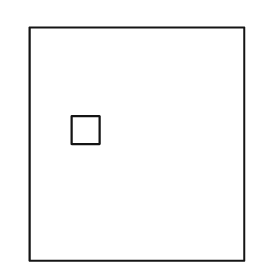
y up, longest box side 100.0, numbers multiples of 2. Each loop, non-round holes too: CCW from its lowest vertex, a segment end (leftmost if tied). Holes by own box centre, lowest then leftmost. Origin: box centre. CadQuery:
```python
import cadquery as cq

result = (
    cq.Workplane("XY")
    .moveTo(-46.0, -50.0)
    .lineTo(46.0, -50.0)
    .lineTo(46.0, 50.0)
    .lineTo(-46.0, 50.0)
    .close()
    .moveTo(-28.0, 0.0)
    .lineTo(-16.0, 0.0)
    .lineTo(-16.0, 12.0)
    .lineTo(-28.0, 12.0)
    .close()
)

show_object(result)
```